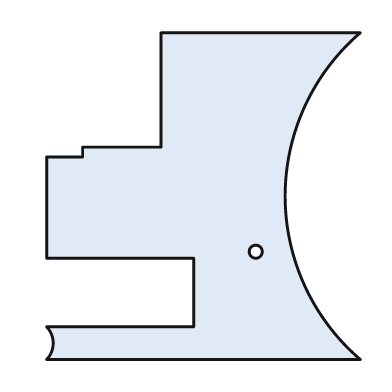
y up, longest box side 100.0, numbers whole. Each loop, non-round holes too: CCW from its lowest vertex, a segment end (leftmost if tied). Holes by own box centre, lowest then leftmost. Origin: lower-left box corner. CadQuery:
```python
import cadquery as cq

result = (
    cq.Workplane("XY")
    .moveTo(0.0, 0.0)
    .lineTo(96.0, 0.0)
    .threePointArc((73.0, 50.0), (96.0, 100.0))
    .lineTo(35.0, 100.0)
    .lineTo(35.0, 65.0)
    .lineTo(11.0, 65.0)
    .lineTo(11.0, 62.0)
    .lineTo(0.0, 62.0)
    .lineTo(0.0, 31.0)
    .lineTo(45.0, 31.0)
    .lineTo(45.0, 10.0)
    .lineTo(0.0, 10.0)
    .threePointArc((2.0, 5.0), (0.0, 0.0))
    .close()
    .moveTo(64.0, 33.0)
    .circle(2.0)
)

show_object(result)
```